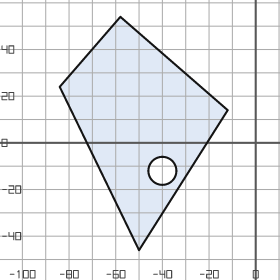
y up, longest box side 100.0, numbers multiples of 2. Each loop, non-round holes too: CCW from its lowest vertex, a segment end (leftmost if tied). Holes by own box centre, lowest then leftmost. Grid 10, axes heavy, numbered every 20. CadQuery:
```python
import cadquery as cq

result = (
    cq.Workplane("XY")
    .moveTo(-50.0, -46.0)
    .lineTo(-12.0, 14.0)
    .lineTo(-58.0, 54.0)
    .lineTo(-84.0, 24.0)
    .close()
    .moveTo(-40.0, -12.0)
    .circle(6.0)
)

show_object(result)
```